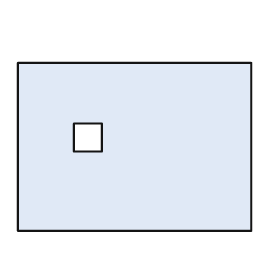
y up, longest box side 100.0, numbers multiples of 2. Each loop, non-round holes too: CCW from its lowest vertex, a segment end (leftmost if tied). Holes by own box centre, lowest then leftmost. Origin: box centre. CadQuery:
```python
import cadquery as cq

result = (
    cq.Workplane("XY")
    .moveTo(-50.0, -36.0)
    .lineTo(50.0, -36.0)
    .lineTo(50.0, 36.0)
    .lineTo(-50.0, 36.0)
    .close()
    .moveTo(-26.0, -2.0)
    .lineTo(-14.0, -2.0)
    .lineTo(-14.0, 10.0)
    .lineTo(-26.0, 10.0)
    .close()
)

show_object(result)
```